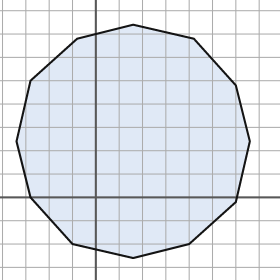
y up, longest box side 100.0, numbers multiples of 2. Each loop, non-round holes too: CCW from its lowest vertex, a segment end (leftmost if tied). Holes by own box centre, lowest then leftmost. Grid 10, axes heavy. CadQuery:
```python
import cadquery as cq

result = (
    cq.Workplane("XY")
    .moveTo(16.0, -26.0)
    .lineTo(40.0, -20.0)
    .lineTo(60.0, -2.0)
    .lineTo(66.0, 24.0)
    .lineTo(60.0, 48.0)
    .lineTo(42.0, 68.0)
    .lineTo(16.0, 74.0)
    .lineTo(-8.0, 68.0)
    .lineTo(-28.0, 50.0)
    .lineTo(-34.0, 24.0)
    .lineTo(-28.0, 0.0)
    .lineTo(-10.0, -20.0)
    .close()
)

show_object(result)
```